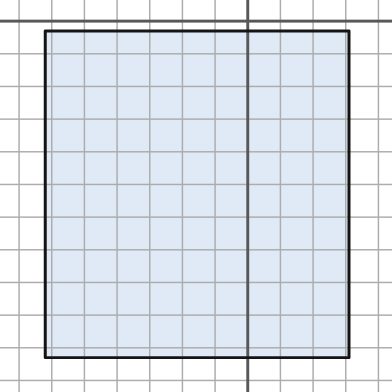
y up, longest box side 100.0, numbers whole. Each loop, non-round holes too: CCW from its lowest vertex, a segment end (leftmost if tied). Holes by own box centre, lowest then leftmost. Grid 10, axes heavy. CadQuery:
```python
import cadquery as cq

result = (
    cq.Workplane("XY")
    .moveTo(-62.0, -103.0)
    .lineTo(31.0, -103.0)
    .lineTo(31.0, -3.0)
    .lineTo(-62.0, -3.0)
    .close()
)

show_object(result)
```